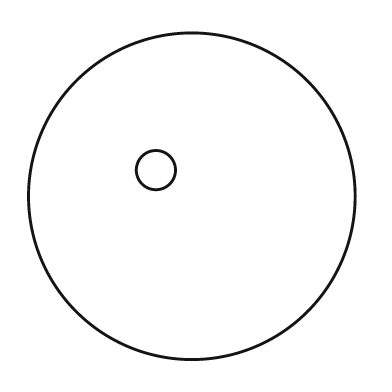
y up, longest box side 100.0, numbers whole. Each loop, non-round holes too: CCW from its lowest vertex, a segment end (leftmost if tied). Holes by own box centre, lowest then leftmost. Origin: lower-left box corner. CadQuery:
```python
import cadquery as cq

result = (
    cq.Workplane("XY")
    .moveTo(50.0, 50.0)
    .circle(50.0)
    .moveTo(39.0, 58.0)
    .circle(6.0)
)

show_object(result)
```